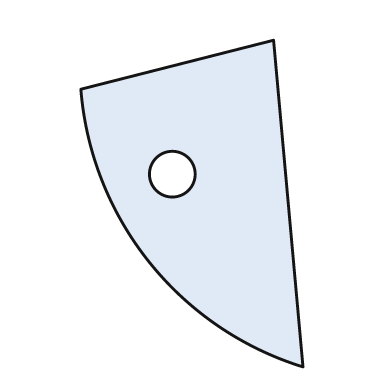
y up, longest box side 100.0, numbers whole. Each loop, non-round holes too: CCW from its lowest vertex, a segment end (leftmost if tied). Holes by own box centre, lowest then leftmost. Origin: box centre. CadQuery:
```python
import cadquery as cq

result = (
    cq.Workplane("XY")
    .moveTo(34.0, -50.0)
    .lineTo(25.0, 50.0)
    .lineTo(-34.0, 35.0)
    .threePointArc((-13.0, -18.0), (34.0, -50.0))
    .close()
    .moveTo(-6.0, 9.0)
    .circle(7.0)
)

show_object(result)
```